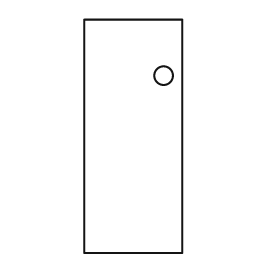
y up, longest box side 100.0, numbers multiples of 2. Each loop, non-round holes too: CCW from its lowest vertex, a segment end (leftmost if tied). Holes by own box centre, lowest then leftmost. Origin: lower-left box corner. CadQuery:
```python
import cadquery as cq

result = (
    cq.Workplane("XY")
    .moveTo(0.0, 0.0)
    .lineTo(42.0, 0.0)
    .lineTo(42.0, 100.0)
    .lineTo(0.0, 100.0)
    .close()
    .moveTo(34.0, 76.0)
    .circle(4.0)
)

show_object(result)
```